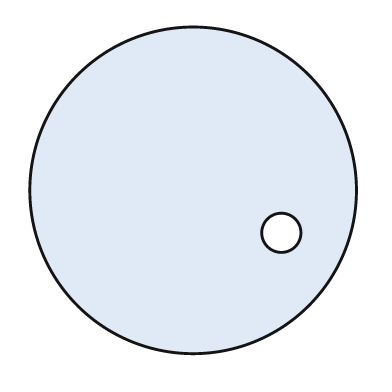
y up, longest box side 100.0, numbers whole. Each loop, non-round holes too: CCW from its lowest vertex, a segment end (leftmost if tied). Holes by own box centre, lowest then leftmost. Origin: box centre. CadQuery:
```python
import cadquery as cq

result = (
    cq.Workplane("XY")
    .moveTo(0.0, 0.0)
    .circle(50.0)
    .moveTo(27.0, -13.0)
    .circle(6.0)
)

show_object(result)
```